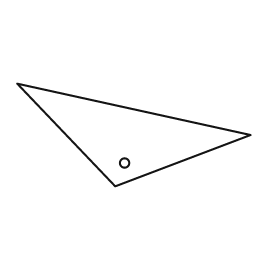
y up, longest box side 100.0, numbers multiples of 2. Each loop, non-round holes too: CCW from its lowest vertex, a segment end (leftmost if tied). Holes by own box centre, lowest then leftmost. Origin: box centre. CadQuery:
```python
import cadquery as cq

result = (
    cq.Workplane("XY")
    .moveTo(-8.0, -22.0)
    .lineTo(50.0, 0.0)
    .lineTo(-50.0, 22.0)
    .close()
    .moveTo(-4.0, -12.0)
    .circle(2.0)
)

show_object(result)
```